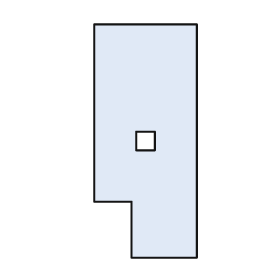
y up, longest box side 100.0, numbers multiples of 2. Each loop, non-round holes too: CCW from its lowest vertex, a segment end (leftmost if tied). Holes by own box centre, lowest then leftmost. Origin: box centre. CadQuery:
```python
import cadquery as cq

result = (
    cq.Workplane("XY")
    .moveTo(-6.0, -50.0)
    .lineTo(22.0, -50.0)
    .lineTo(22.0, 50.0)
    .lineTo(-22.0, 50.0)
    .lineTo(-22.0, -26.0)
    .lineTo(-6.0, -26.0)
    .close()
    .moveTo(-4.0, -4.0)
    .lineTo(4.0, -4.0)
    .lineTo(4.0, 4.0)
    .lineTo(-4.0, 4.0)
    .close()
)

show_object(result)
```